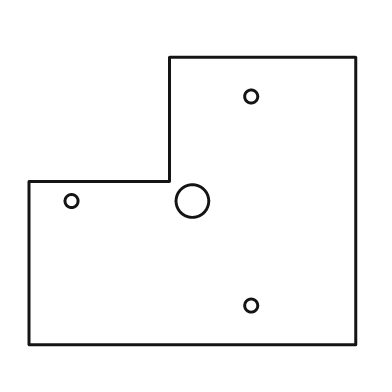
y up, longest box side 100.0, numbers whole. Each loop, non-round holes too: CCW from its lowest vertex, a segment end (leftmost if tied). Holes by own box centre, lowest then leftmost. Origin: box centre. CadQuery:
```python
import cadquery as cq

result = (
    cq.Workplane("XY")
    .moveTo(-50.0, -44.0)
    .lineTo(50.0, -44.0)
    .lineTo(50.0, 44.0)
    .lineTo(-7.0, 44.0)
    .lineTo(-7.0, 6.0)
    .lineTo(-50.0, 6.0)
    .close()
    .moveTo(18.0, -32.0)
    .circle(2.0)
    .moveTo(-37.0, 0.0)
    .circle(2.0)
    .moveTo(0.0, 0.0)
    .circle(5.0)
    .moveTo(18.0, 32.0)
    .circle(2.0)
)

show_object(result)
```